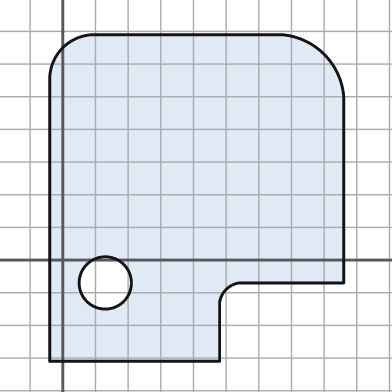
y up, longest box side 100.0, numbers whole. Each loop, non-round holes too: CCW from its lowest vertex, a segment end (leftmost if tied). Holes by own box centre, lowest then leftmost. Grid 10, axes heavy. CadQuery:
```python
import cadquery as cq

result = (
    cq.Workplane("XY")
    .moveTo(-4.0, -31.0)
    .lineTo(48.0, -31.0)
    .lineTo(48.0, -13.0)
    .threePointArc((50.0, -9.0), (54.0, -7.0))
    .lineTo(86.0, -7.0)
    .lineTo(86.0, 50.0)
    .threePointArc((80.0, 63.0), (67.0, 69.0))
    .lineTo(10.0, 69.0)
    .threePointArc((0.0, 65.0), (-4.0, 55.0))
    .close()
    .moveTo(13.0, -7.0)
    .circle(8.0)
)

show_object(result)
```